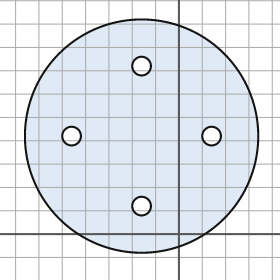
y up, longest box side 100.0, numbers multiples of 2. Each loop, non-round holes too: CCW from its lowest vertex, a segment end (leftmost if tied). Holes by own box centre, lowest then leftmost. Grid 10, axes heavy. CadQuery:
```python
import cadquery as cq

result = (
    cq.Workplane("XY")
    .moveTo(-16.0, 42.0)
    .circle(50.0)
    .moveTo(-16.0, 12.0)
    .circle(4.0)
    .moveTo(-46.0, 42.0)
    .circle(4.0)
    .moveTo(14.0, 42.0)
    .circle(4.0)
    .moveTo(-16.0, 72.0)
    .circle(4.0)
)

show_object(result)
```